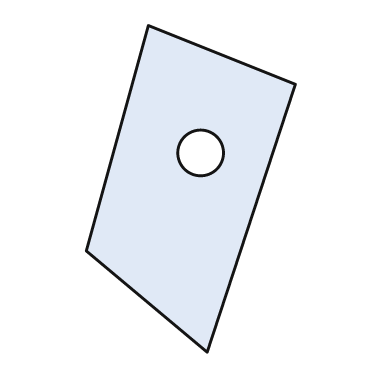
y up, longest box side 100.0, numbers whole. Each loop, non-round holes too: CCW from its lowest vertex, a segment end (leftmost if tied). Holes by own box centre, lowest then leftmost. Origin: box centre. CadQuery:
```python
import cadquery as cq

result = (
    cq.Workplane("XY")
    .moveTo(5.0, -50.0)
    .lineTo(32.0, 32.0)
    .lineTo(-13.0, 50.0)
    .lineTo(-32.0, -19.0)
    .close()
    .moveTo(3.0, 11.0)
    .circle(7.0)
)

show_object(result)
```